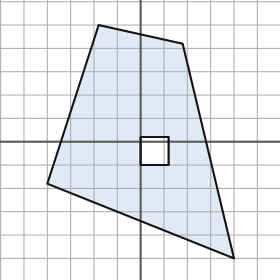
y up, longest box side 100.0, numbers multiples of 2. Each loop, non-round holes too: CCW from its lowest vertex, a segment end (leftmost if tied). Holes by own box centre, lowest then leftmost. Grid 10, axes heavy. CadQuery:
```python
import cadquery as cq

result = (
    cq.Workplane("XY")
    .moveTo(40.0, -50.0)
    .lineTo(18.0, 42.0)
    .lineTo(-18.0, 50.0)
    .lineTo(-40.0, -18.0)
    .close()
    .moveTo(0.0, -10.0)
    .lineTo(12.0, -10.0)
    .lineTo(12.0, 2.0)
    .lineTo(0.0, 2.0)
    .close()
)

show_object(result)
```